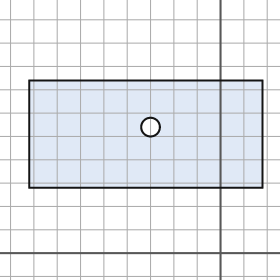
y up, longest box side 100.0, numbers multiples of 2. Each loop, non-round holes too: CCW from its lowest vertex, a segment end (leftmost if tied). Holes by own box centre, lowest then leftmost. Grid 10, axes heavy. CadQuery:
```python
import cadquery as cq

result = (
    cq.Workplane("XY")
    .moveTo(-82.0, 28.0)
    .lineTo(18.0, 28.0)
    .lineTo(18.0, 74.0)
    .lineTo(-82.0, 74.0)
    .close()
    .moveTo(-30.0, 54.0)
    .circle(4.0)
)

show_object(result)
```